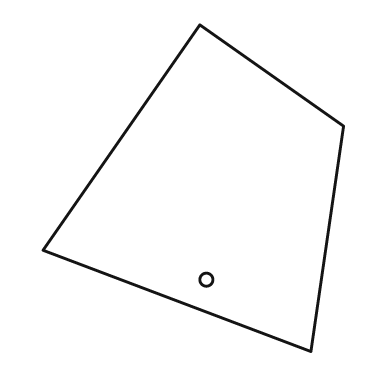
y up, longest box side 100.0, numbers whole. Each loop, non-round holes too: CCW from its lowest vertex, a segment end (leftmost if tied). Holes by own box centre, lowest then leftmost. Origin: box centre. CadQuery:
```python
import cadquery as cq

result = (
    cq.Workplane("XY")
    .moveTo(36.0, -50.0)
    .lineTo(46.0, 19.0)
    .lineTo(2.0, 50.0)
    .lineTo(-46.0, -19.0)
    .close()
    .moveTo(4.0, -28.0)
    .circle(2.0)
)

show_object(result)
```